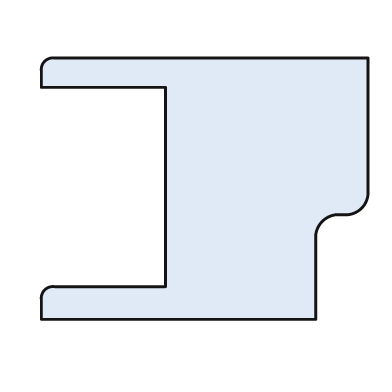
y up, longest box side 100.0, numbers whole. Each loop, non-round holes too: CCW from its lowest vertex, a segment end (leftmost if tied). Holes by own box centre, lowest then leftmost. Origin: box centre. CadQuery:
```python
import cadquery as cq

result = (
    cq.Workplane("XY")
    .moveTo(-50.0, -40.0)
    .lineTo(34.0, -40.0)
    .lineTo(34.0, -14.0)
    .threePointArc((36.0, -10.0), (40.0, -8.0))
    .lineTo(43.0, -8.0)
    .threePointArc((48.0, -6.0), (50.0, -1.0))
    .lineTo(50.0, 40.0)
    .lineTo(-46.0, 40.0)
    .threePointArc((-49.0, 39.0), (-50.0, 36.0))
    .lineTo(-50.0, 31.0)
    .lineTo(-12.0, 31.0)
    .lineTo(-12.0, -30.0)
    .lineTo(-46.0, -30.0)
    .threePointArc((-49.0, -31.0), (-50.0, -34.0))
    .close()
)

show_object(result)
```